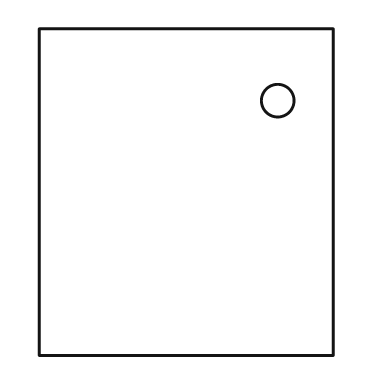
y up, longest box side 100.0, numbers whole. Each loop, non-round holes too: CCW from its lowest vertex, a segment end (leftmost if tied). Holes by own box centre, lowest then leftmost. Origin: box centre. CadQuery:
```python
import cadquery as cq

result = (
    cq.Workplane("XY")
    .moveTo(-45.0, -50.0)
    .lineTo(45.0, -50.0)
    .lineTo(45.0, 50.0)
    .lineTo(-45.0, 50.0)
    .close()
    .moveTo(28.0, 28.0)
    .circle(5.0)
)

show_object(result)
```